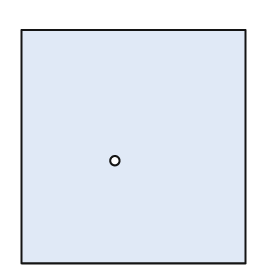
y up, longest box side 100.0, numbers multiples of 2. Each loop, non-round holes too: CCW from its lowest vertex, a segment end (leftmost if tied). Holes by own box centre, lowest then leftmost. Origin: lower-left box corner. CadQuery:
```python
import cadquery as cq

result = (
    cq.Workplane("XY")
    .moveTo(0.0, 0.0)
    .lineTo(96.0, 0.0)
    .lineTo(96.0, 100.0)
    .lineTo(0.0, 100.0)
    .close()
    .moveTo(40.0, 44.0)
    .circle(2.0)
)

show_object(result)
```